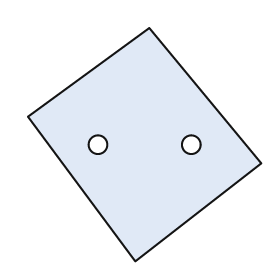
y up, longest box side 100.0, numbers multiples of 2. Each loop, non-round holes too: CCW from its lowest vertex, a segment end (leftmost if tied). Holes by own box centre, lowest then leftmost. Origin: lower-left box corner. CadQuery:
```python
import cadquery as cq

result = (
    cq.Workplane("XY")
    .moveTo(46.0, 0.0)
    .lineTo(100.0, 42.0)
    .lineTo(52.0, 100.0)
    .lineTo(0.0, 62.0)
    .close()
    .moveTo(30.0, 50.0)
    .circle(4.0)
    .moveTo(70.0, 50.0)
    .circle(4.0)
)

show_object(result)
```